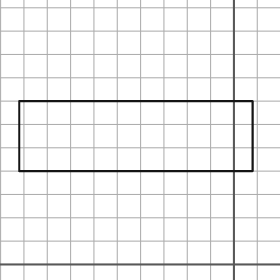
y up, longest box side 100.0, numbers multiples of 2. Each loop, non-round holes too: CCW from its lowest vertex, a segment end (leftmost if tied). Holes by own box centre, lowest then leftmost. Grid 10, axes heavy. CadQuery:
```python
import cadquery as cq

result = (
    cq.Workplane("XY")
    .moveTo(-92.0, 40.0)
    .lineTo(8.0, 40.0)
    .lineTo(8.0, 70.0)
    .lineTo(-92.0, 70.0)
    .close()
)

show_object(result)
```